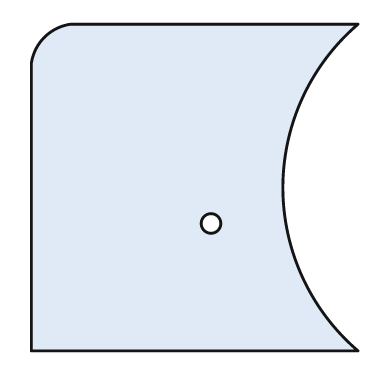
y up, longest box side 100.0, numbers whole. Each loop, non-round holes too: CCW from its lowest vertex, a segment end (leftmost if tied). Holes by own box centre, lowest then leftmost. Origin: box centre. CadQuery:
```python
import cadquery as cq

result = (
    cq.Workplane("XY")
    .moveTo(-50.0, -50.0)
    .lineTo(50.0, -50.0)
    .threePointArc((27.0, 0.0), (50.0, 50.0))
    .lineTo(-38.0, 50.0)
    .threePointArc((-46.0, 46.0), (-50.0, 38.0))
    .close()
    .moveTo(5.0, -11.0)
    .circle(3.0)
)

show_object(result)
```